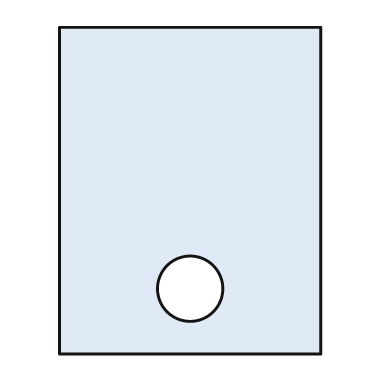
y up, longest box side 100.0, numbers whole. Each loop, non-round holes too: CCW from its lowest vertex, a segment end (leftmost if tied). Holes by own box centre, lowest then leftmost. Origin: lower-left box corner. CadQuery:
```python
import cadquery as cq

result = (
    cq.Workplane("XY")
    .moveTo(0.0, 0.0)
    .lineTo(80.0, 0.0)
    .lineTo(80.0, 100.0)
    .lineTo(0.0, 100.0)
    .close()
    .moveTo(40.0, 20.0)
    .circle(10.0)
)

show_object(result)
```